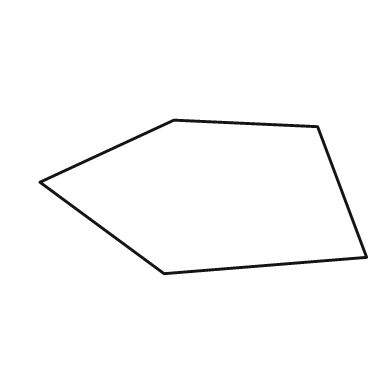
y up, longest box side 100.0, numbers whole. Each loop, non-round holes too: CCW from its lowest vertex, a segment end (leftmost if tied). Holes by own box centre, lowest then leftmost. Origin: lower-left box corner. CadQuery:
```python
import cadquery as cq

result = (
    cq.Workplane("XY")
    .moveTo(38.0, 0.0)
    .lineTo(100.0, 5.0)
    .lineTo(85.0, 45.0)
    .lineTo(41.0, 47.0)
    .lineTo(0.0, 28.0)
    .close()
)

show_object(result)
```